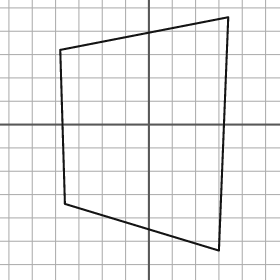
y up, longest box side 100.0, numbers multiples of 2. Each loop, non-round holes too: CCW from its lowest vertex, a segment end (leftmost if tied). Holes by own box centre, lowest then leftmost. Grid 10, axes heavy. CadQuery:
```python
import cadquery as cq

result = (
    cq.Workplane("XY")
    .moveTo(30.0, -54.0)
    .lineTo(34.0, 46.0)
    .lineTo(-38.0, 32.0)
    .lineTo(-36.0, -34.0)
    .close()
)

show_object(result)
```